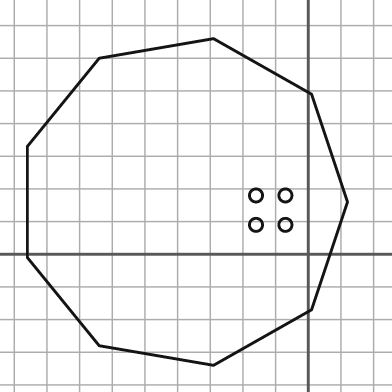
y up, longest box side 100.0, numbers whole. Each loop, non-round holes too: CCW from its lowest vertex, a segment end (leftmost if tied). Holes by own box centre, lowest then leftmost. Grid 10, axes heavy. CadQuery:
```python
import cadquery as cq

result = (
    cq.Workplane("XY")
    .moveTo(-29.0, -34.0)
    .lineTo(1.0, -17.0)
    .lineTo(12.0, 16.0)
    .lineTo(1.0, 49.0)
    .lineTo(-29.0, 66.0)
    .lineTo(-64.0, 60.0)
    .lineTo(-86.0, 33.0)
    .lineTo(-86.0, -1.0)
    .lineTo(-64.0, -28.0)
    .close()
    .moveTo(-16.0, 9.0)
    .circle(2.0)
    .moveTo(-7.0, 9.0)
    .circle(2.0)
    .moveTo(-16.0, 18.0)
    .circle(2.0)
    .moveTo(-7.0, 18.0)
    .circle(2.0)
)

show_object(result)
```